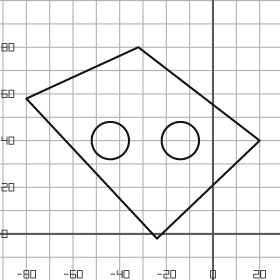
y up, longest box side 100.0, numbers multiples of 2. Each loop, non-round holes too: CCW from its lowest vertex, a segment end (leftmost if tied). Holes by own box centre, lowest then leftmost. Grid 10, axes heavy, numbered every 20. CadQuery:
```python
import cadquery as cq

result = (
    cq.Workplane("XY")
    .moveTo(-24.0, -2.0)
    .lineTo(20.0, 40.0)
    .lineTo(-32.0, 80.0)
    .lineTo(-80.0, 58.0)
    .close()
    .moveTo(-44.0, 40.0)
    .circle(8.0)
    .moveTo(-14.0, 40.0)
    .circle(8.0)
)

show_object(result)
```